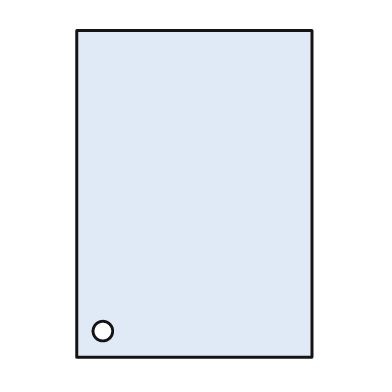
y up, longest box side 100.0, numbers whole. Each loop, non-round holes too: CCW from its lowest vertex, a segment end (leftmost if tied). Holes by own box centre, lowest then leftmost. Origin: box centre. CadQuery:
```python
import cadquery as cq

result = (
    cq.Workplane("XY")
    .moveTo(-36.0, -50.0)
    .lineTo(36.0, -50.0)
    .lineTo(36.0, 50.0)
    .lineTo(-36.0, 50.0)
    .close()
    .moveTo(-28.0, -42.0)
    .circle(3.0)
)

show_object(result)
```